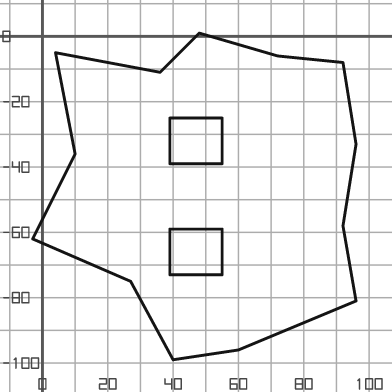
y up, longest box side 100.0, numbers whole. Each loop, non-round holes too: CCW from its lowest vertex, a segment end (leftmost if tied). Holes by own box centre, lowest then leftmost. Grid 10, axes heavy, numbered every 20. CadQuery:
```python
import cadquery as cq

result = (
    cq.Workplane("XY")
    .moveTo(40.0, -99.0)
    .lineTo(60.0, -96.0)
    .lineTo(96.0, -81.0)
    .lineTo(92.0, -58.0)
    .lineTo(96.0, -33.0)
    .lineTo(92.0, -8.0)
    .lineTo(72.0, -6.0)
    .lineTo(48.0, 1.0)
    .lineTo(36.0, -11.0)
    .lineTo(4.0, -5.0)
    .lineTo(10.0, -36.0)
    .lineTo(-3.0, -62.0)
    .lineTo(27.0, -75.0)
    .close()
    .moveTo(39.0, -73.0)
    .lineTo(55.0, -73.0)
    .lineTo(55.0, -59.0)
    .lineTo(39.0, -59.0)
    .close()
    .moveTo(39.0, -39.0)
    .lineTo(55.0, -39.0)
    .lineTo(55.0, -25.0)
    .lineTo(39.0, -25.0)
    .close()
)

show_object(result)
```